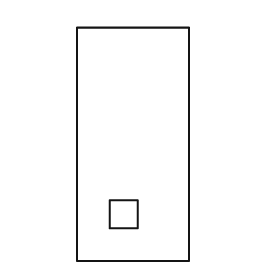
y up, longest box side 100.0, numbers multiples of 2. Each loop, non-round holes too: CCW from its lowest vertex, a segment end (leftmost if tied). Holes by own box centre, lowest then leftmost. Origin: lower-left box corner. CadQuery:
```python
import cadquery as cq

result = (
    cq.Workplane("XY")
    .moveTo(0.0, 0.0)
    .lineTo(48.0, 0.0)
    .lineTo(48.0, 100.0)
    .lineTo(0.0, 100.0)
    .close()
    .moveTo(14.0, 14.0)
    .lineTo(26.0, 14.0)
    .lineTo(26.0, 26.0)
    .lineTo(14.0, 26.0)
    .close()
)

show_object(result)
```